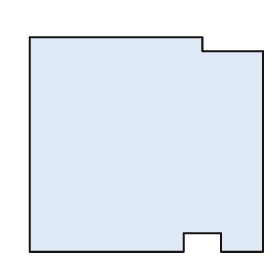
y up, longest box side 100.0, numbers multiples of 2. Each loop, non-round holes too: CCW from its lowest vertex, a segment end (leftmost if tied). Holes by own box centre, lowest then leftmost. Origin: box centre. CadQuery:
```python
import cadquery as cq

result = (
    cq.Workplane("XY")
    .moveTo(-50.0, -46.0)
    .lineTo(16.0, -46.0)
    .lineTo(16.0, -38.0)
    .lineTo(32.0, -38.0)
    .lineTo(32.0, -46.0)
    .lineTo(50.0, -46.0)
    .lineTo(50.0, 40.0)
    .lineTo(24.0, 40.0)
    .lineTo(24.0, 46.0)
    .lineTo(-50.0, 46.0)
    .close()
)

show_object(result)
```